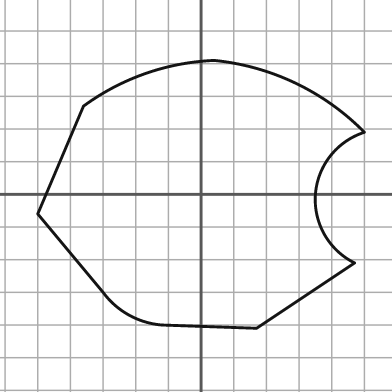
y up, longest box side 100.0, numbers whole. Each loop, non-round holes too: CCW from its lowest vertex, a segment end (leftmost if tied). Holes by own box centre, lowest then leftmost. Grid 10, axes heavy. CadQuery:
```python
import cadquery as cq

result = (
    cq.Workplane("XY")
    .moveTo(17.0, -41.0)
    .lineTo(47.0, -21.0)
    .threePointArc((35.0, 0.0), (50.0, 19.0))
    .threePointArc((29.0, 34.0), (4.0, 41.0))
    .threePointArc((-17.0, 37.0), (-36.0, 27.0))
    .lineTo(-50.0, -6.0)
    .lineTo(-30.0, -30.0)
    .threePointArc((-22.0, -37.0), (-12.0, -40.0))
    .close()
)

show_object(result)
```